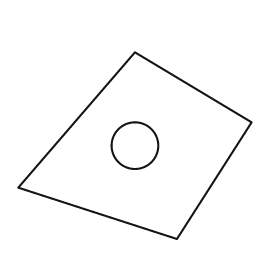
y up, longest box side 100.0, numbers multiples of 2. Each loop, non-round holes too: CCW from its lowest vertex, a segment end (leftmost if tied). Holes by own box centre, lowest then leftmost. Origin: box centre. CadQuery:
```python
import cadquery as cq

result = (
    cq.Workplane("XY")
    .moveTo(18.0, -40.0)
    .lineTo(50.0, 10.0)
    .lineTo(0.0, 40.0)
    .lineTo(-50.0, -18.0)
    .close()
    .moveTo(0.0, 0.0)
    .circle(10.0)
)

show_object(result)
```